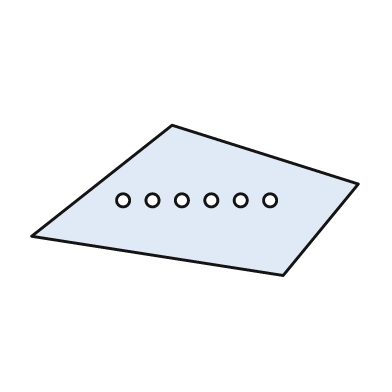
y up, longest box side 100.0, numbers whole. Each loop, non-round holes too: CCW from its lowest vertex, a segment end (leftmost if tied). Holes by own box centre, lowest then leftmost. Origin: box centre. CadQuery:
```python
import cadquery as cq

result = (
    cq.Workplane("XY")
    .moveTo(27.0, -23.0)
    .lineTo(50.0, 5.0)
    .lineTo(-7.0, 23.0)
    .lineTo(-50.0, -11.0)
    .close()
    .moveTo(-22.0, 0.0)
    .circle(2.0)
    .moveTo(-13.0, 0.0)
    .circle(2.0)
    .moveTo(-4.0, 0.0)
    .circle(2.0)
    .moveTo(5.0, 0.0)
    .circle(2.0)
    .moveTo(14.0, 0.0)
    .circle(2.0)
    .moveTo(23.0, 0.0)
    .circle(2.0)
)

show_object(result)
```